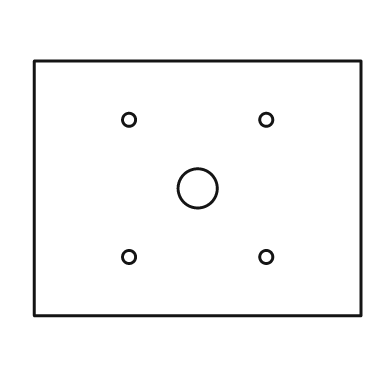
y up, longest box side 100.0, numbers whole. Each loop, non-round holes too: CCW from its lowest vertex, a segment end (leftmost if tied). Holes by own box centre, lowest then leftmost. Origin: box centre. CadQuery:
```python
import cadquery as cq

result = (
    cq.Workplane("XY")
    .moveTo(-50.0, -39.0)
    .lineTo(50.0, -39.0)
    .lineTo(50.0, 39.0)
    .lineTo(-50.0, 39.0)
    .close()
    .moveTo(-21.0, -21.0)
    .circle(2.0)
    .moveTo(21.0, -21.0)
    .circle(2.0)
    .moveTo(0.0, 0.0)
    .circle(6.0)
    .moveTo(-21.0, 21.0)
    .circle(2.0)
    .moveTo(21.0, 21.0)
    .circle(2.0)
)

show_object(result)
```